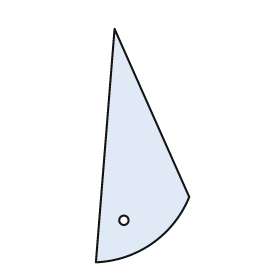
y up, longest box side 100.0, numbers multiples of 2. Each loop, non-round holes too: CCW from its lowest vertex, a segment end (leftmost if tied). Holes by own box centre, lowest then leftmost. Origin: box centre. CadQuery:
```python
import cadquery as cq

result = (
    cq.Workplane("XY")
    .moveTo(-20.0, -50.0)
    .threePointArc((4.0, -42.0), (20.0, -22.0))
    .lineTo(-12.0, 50.0)
    .close()
    .moveTo(-8.0, -32.0)
    .circle(2.0)
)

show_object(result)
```